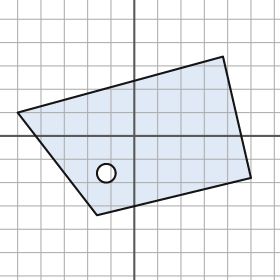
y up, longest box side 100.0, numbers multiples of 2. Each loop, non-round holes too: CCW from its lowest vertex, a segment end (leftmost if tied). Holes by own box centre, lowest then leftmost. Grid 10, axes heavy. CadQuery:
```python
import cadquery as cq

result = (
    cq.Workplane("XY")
    .moveTo(-16.0, -34.0)
    .lineTo(50.0, -18.0)
    .lineTo(38.0, 34.0)
    .lineTo(-50.0, 10.0)
    .close()
    .moveTo(-12.0, -16.0)
    .circle(4.0)
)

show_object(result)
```